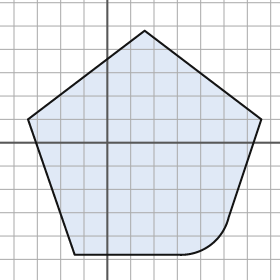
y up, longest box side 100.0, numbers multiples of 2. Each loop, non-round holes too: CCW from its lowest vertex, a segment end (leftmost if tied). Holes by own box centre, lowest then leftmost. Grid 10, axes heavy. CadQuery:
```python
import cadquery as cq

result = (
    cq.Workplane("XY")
    .moveTo(-14.0, -48.0)
    .lineTo(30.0, -48.0)
    .threePointArc((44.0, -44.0), (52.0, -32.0))
    .lineTo(66.0, 10.0)
    .lineTo(16.0, 48.0)
    .lineTo(-34.0, 10.0)
    .close()
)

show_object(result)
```